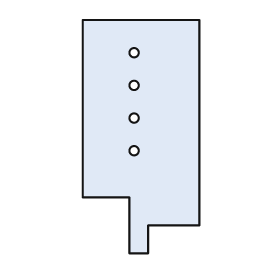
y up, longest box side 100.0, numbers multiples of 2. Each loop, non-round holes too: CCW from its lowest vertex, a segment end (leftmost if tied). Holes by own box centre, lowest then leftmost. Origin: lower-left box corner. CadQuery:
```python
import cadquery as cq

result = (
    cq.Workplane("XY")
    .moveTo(20.0, 0.0)
    .lineTo(28.0, 0.0)
    .lineTo(28.0, 12.0)
    .lineTo(50.0, 12.0)
    .lineTo(50.0, 100.0)
    .lineTo(0.0, 100.0)
    .lineTo(0.0, 24.0)
    .lineTo(20.0, 24.0)
    .close()
    .moveTo(22.0, 44.0)
    .circle(2.0)
    .moveTo(22.0, 58.0)
    .circle(2.0)
    .moveTo(22.0, 72.0)
    .circle(2.0)
    .moveTo(22.0, 86.0)
    .circle(2.0)
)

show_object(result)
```